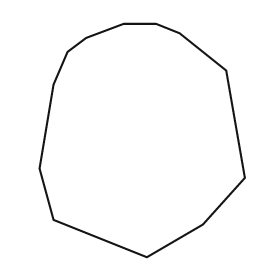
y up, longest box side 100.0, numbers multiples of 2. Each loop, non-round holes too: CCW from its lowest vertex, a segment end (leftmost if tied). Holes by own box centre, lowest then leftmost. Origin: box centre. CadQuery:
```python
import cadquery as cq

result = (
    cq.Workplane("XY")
    .moveTo(2.0, -50.0)
    .lineTo(26.0, -36.0)
    .lineTo(44.0, -16.0)
    .lineTo(36.0, 30.0)
    .lineTo(16.0, 46.0)
    .lineTo(6.0, 50.0)
    .lineTo(-8.0, 50.0)
    .lineTo(-24.0, 44.0)
    .lineTo(-32.0, 38.0)
    .lineTo(-38.0, 24.0)
    .lineTo(-44.0, -12.0)
    .lineTo(-38.0, -34.0)
    .close()
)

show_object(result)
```